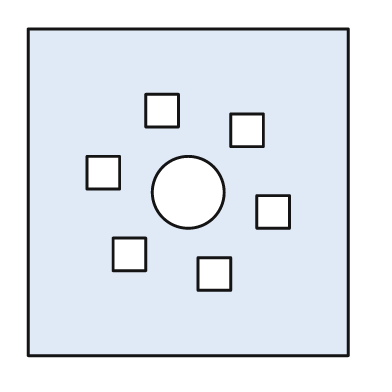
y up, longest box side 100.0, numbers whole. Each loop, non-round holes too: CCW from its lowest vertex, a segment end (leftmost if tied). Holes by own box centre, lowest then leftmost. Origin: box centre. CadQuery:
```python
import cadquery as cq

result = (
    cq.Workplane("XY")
    .moveTo(-49.0, -50.0)
    .lineTo(49.0, -50.0)
    .lineTo(49.0, 50.0)
    .lineTo(-49.0, 50.0)
    .close()
    .moveTo(3.0, -30.0)
    .lineTo(13.0, -30.0)
    .lineTo(13.0, -20.0)
    .lineTo(3.0, -20.0)
    .close()
    .moveTo(-23.0, -24.0)
    .lineTo(-13.0, -24.0)
    .lineTo(-13.0, -14.0)
    .lineTo(-23.0, -14.0)
    .close()
    .moveTo(21.0, -11.0)
    .lineTo(31.0, -11.0)
    .lineTo(31.0, -1.0)
    .lineTo(21.0, -1.0)
    .close()
    .moveTo(0.0, 0.0)
    .circle(11.0)
    .moveTo(-31.0, 1.0)
    .lineTo(-21.0, 1.0)
    .lineTo(-21.0, 11.0)
    .lineTo(-31.0, 11.0)
    .close()
    .moveTo(13.0, 14.0)
    .lineTo(23.0, 14.0)
    .lineTo(23.0, 24.0)
    .lineTo(13.0, 24.0)
    .close()
    .moveTo(-13.0, 20.0)
    .lineTo(-3.0, 20.0)
    .lineTo(-3.0, 30.0)
    .lineTo(-13.0, 30.0)
    .close()
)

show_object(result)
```